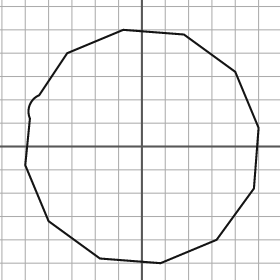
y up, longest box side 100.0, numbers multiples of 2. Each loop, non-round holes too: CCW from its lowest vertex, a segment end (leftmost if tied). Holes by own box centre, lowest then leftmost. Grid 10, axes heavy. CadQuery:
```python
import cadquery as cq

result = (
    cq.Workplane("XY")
    .moveTo(8.0, -50.0)
    .lineTo(32.0, -40.0)
    .lineTo(48.0, -18.0)
    .lineTo(50.0, 8.0)
    .lineTo(40.0, 32.0)
    .lineTo(18.0, 48.0)
    .lineTo(-8.0, 50.0)
    .lineTo(-32.0, 40.0)
    .lineTo(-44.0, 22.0)
    .threePointArc((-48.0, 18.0), (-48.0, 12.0))
    .lineTo(-50.0, -8.0)
    .lineTo(-40.0, -32.0)
    .lineTo(-18.0, -48.0)
    .close()
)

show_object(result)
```